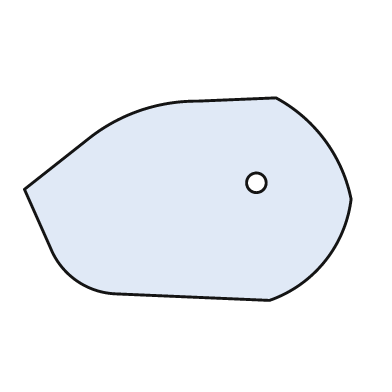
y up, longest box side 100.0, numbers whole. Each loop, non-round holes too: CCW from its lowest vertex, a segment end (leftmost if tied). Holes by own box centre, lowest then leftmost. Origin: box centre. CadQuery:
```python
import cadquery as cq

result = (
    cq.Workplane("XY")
    .moveTo(25.0, -31.0)
    .threePointArc((42.0, -19.0), (50.0, 0.0))
    .threePointArc((42.0, 18.0), (27.0, 31.0))
    .lineTo(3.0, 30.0)
    .threePointArc((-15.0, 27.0), (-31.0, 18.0))
    .lineTo(-50.0, 3.0)
    .lineTo(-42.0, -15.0)
    .threePointArc((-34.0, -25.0), (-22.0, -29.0))
    .close()
    .moveTo(21.0, 5.0)
    .circle(3.0)
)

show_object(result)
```